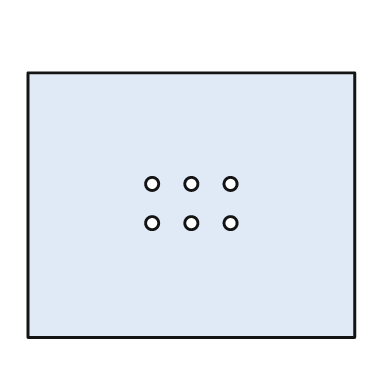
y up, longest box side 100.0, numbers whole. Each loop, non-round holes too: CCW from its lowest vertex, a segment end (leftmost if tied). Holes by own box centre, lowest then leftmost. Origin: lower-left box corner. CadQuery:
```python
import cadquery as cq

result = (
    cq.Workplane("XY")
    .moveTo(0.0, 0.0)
    .lineTo(100.0, 0.0)
    .lineTo(100.0, 81.0)
    .lineTo(0.0, 81.0)
    .close()
    .moveTo(38.0, 35.0)
    .circle(2.0)
    .moveTo(50.0, 35.0)
    .circle(2.0)
    .moveTo(62.0, 35.0)
    .circle(2.0)
    .moveTo(38.0, 47.0)
    .circle(2.0)
    .moveTo(50.0, 47.0)
    .circle(2.0)
    .moveTo(62.0, 47.0)
    .circle(2.0)
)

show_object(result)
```